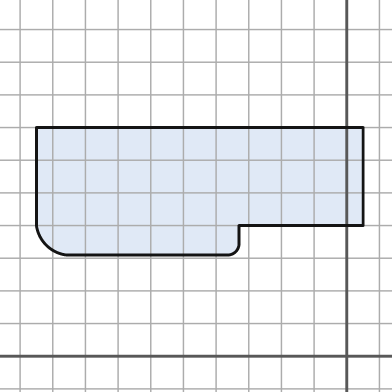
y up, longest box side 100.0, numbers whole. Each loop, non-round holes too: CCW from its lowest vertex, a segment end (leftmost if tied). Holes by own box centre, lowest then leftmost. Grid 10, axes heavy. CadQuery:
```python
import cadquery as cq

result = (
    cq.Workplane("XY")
    .moveTo(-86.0, 31.0)
    .lineTo(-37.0, 31.0)
    .threePointArc((-34.0, 32.0), (-33.0, 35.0))
    .lineTo(-33.0, 40.0)
    .lineTo(5.0, 40.0)
    .lineTo(5.0, 70.0)
    .lineTo(-95.0, 70.0)
    .lineTo(-95.0, 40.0)
    .threePointArc((-92.0, 34.0), (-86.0, 31.0))
    .close()
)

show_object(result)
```